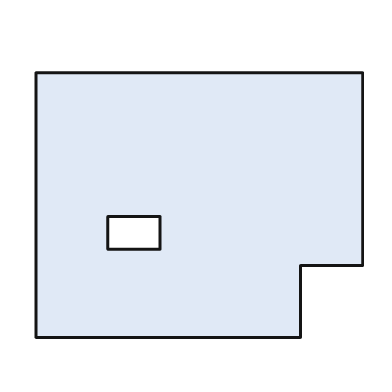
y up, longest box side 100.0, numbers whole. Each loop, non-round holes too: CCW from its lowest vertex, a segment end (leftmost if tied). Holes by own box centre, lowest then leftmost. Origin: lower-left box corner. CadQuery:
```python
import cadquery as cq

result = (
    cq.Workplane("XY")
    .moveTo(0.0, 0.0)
    .lineTo(81.0, 0.0)
    .lineTo(81.0, 22.0)
    .lineTo(100.0, 22.0)
    .lineTo(100.0, 81.0)
    .lineTo(0.0, 81.0)
    .close()
    .moveTo(22.0, 27.0)
    .lineTo(38.0, 27.0)
    .lineTo(38.0, 37.0)
    .lineTo(22.0, 37.0)
    .close()
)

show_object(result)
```